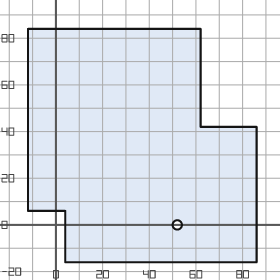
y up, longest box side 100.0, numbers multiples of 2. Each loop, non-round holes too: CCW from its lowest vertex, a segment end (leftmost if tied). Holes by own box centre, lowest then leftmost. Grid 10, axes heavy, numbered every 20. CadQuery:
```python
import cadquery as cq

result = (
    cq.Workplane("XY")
    .moveTo(4.0, -16.0)
    .lineTo(86.0, -16.0)
    .lineTo(86.0, 42.0)
    .lineTo(62.0, 42.0)
    .lineTo(62.0, 84.0)
    .lineTo(-12.0, 84.0)
    .lineTo(-12.0, 6.0)
    .lineTo(4.0, 6.0)
    .close()
    .moveTo(52.0, 0.0)
    .circle(2.0)
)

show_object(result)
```